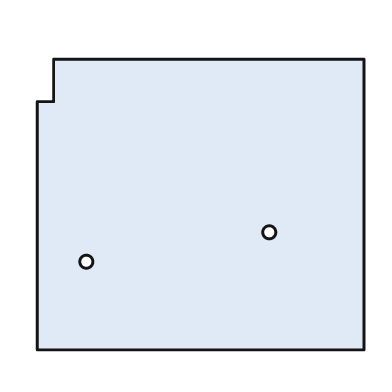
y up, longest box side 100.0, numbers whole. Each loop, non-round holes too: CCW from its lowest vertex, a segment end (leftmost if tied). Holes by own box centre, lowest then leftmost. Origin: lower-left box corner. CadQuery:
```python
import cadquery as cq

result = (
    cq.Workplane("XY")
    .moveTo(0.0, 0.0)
    .lineTo(100.0, 0.0)
    .lineTo(100.0, 89.0)
    .lineTo(5.0, 89.0)
    .lineTo(5.0, 76.0)
    .lineTo(0.0, 76.0)
    .close()
    .moveTo(15.0, 27.0)
    .circle(2.0)
    .moveTo(71.0, 36.0)
    .circle(2.0)
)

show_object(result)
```